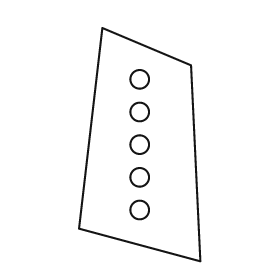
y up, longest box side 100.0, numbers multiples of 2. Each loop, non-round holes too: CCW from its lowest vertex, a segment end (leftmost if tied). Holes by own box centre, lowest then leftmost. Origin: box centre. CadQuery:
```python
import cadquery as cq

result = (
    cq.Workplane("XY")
    .moveTo(26.0, -50.0)
    .lineTo(22.0, 34.0)
    .lineTo(-16.0, 50.0)
    .lineTo(-26.0, -36.0)
    .close()
    .moveTo(0.0, -28.0)
    .circle(4.0)
    .moveTo(0.0, -14.0)
    .circle(4.0)
    .moveTo(0.0, 0.0)
    .circle(4.0)
    .moveTo(0.0, 14.0)
    .circle(4.0)
    .moveTo(0.0, 28.0)
    .circle(4.0)
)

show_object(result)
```